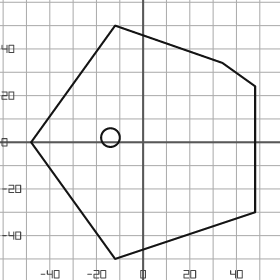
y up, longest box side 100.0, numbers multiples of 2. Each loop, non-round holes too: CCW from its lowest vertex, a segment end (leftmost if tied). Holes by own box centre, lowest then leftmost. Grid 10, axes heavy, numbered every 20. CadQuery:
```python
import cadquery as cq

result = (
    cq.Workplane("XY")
    .moveTo(-12.0, -50.0)
    .lineTo(48.0, -30.0)
    .lineTo(48.0, 24.0)
    .lineTo(34.0, 34.0)
    .lineTo(-12.0, 50.0)
    .lineTo(-48.0, 0.0)
    .close()
    .moveTo(-14.0, 2.0)
    .circle(4.0)
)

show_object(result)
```